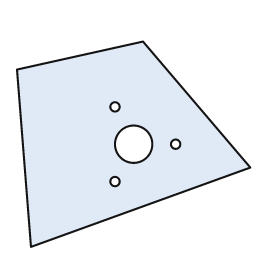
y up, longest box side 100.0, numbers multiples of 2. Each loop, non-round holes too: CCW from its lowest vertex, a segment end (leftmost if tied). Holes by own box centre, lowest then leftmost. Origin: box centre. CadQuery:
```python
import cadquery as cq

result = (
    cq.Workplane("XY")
    .moveTo(-44.0, -44.0)
    .lineTo(50.0, -10.0)
    .lineTo(4.0, 44.0)
    .lineTo(-50.0, 32.0)
    .close()
    .moveTo(-8.0, -16.0)
    .circle(2.0)
    .moveTo(0.0, 0.0)
    .circle(8.0)
    .moveTo(18.0, 0.0)
    .circle(2.0)
    .moveTo(-8.0, 16.0)
    .circle(2.0)
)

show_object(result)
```